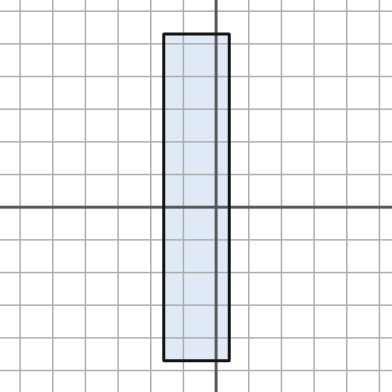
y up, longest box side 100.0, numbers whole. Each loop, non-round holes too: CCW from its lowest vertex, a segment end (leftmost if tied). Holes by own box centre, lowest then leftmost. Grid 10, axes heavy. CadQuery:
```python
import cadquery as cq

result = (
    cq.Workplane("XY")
    .moveTo(-16.0, -47.0)
    .lineTo(4.0, -47.0)
    .lineTo(4.0, 53.0)
    .lineTo(-16.0, 53.0)
    .close()
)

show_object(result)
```